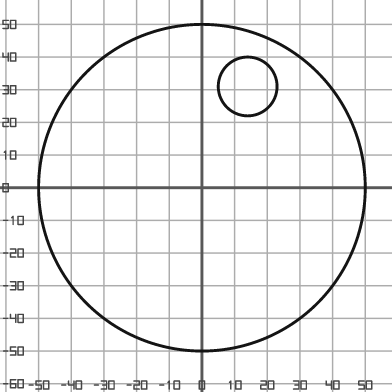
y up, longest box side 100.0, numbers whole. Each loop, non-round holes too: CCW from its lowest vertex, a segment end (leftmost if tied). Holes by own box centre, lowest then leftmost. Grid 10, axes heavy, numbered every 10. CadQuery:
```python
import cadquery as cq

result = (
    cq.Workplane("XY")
    .moveTo(0.0, 0.0)
    .circle(50.0)
    .moveTo(14.0, 31.0)
    .circle(9.0)
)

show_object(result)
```